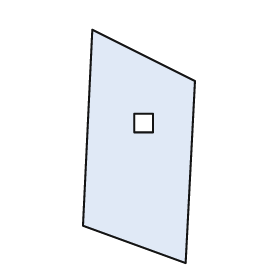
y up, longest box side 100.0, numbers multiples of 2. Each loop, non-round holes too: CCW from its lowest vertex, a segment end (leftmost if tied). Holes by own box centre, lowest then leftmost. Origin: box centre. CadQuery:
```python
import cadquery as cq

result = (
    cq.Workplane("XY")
    .moveTo(20.0, -50.0)
    .lineTo(24.0, 28.0)
    .lineTo(-20.0, 50.0)
    .lineTo(-24.0, -34.0)
    .close()
    .moveTo(-2.0, 6.0)
    .lineTo(6.0, 6.0)
    .lineTo(6.0, 14.0)
    .lineTo(-2.0, 14.0)
    .close()
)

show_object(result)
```